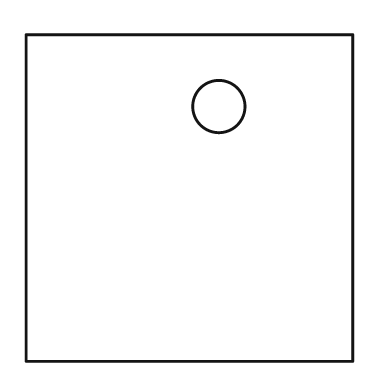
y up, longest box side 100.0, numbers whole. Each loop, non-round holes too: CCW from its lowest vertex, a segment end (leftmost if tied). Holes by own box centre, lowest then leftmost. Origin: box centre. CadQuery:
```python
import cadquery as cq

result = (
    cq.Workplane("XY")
    .moveTo(-50.0, -50.0)
    .lineTo(50.0, -50.0)
    .lineTo(50.0, 50.0)
    .lineTo(-50.0, 50.0)
    .close()
    .moveTo(9.0, 28.0)
    .circle(8.0)
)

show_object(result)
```